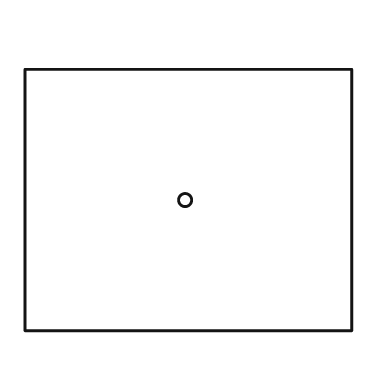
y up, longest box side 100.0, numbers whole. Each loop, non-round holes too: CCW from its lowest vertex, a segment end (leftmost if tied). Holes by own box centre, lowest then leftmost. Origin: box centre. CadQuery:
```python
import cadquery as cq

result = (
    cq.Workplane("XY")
    .moveTo(-50.0, -40.0)
    .lineTo(50.0, -40.0)
    .lineTo(50.0, 40.0)
    .lineTo(-50.0, 40.0)
    .close()
    .moveTo(-1.0, 0.0)
    .circle(2.0)
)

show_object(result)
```